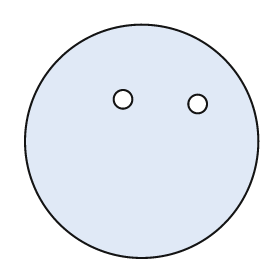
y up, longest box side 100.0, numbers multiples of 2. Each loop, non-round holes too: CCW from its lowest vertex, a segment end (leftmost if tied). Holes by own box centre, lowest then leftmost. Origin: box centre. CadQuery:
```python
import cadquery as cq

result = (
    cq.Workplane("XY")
    .moveTo(0.0, 0.0)
    .circle(50.0)
    .moveTo(24.0, 16.0)
    .circle(4.0)
    .moveTo(-8.0, 18.0)
    .circle(4.0)
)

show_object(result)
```